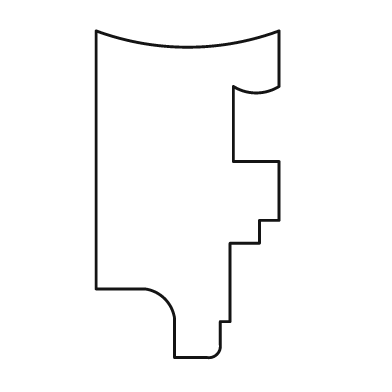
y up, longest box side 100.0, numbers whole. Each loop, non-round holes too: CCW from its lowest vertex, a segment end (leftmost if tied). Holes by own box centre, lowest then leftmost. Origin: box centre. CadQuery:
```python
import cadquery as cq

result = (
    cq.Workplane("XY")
    .moveTo(-4.0, -50.0)
    .lineTo(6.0, -50.0)
    .threePointArc((9.0, -49.0), (10.0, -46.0))
    .lineTo(10.0, -39.0)
    .lineTo(13.0, -39.0)
    .lineTo(13.0, -15.0)
    .lineTo(22.0, -15.0)
    .lineTo(22.0, -8.0)
    .lineTo(28.0, -8.0)
    .lineTo(28.0, 10.0)
    .lineTo(14.0, 10.0)
    .lineTo(14.0, 33.0)
    .threePointArc((21.0, 31.0), (28.0, 33.0))
    .lineTo(28.0, 50.0)
    .threePointArc((0.0, 45.0), (-28.0, 50.0))
    .lineTo(-28.0, -29.0)
    .lineTo(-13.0, -29.0)
    .threePointArc((-7.0, -32.0), (-4.0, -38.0))
    .close()
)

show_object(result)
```